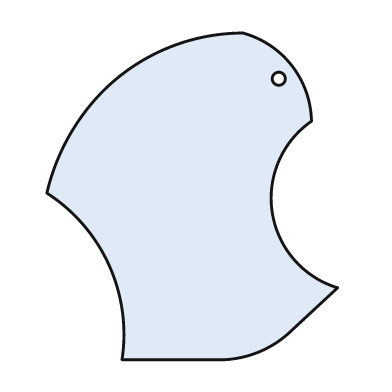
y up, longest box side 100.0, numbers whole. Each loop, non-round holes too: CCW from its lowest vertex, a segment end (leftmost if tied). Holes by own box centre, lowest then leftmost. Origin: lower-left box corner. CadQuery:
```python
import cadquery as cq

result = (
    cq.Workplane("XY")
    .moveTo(23.0, 0.0)
    .lineTo(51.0, 0.0)
    .threePointArc((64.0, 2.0), (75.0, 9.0))
    .lineTo(89.0, 22.0)
    .threePointArc((69.0, 45.0), (81.0, 73.0))
    .threePointArc((75.0, 90.0), (60.0, 100.0))
    .threePointArc((36.0, 95.0), (16.0, 81.0))
    .threePointArc((6.0, 67.0), (0.0, 51.0))
    .threePointArc((19.0, 29.0), (23.0, 0.0))
    .close()
    .moveTo(71.0, 86.0)
    .circle(2.0)
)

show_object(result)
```